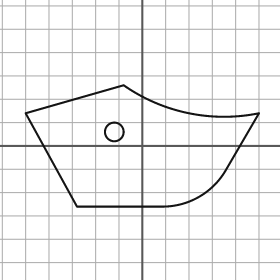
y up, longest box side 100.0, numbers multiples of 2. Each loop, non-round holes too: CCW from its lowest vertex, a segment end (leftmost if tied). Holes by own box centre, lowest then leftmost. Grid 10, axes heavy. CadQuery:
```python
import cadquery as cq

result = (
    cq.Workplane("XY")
    .moveTo(-28.0, -26.0)
    .lineTo(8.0, -26.0)
    .threePointArc((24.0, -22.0), (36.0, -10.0))
    .lineTo(50.0, 14.0)
    .threePointArc((20.0, 14.0), (-8.0, 26.0))
    .lineTo(-50.0, 14.0)
    .close()
    .moveTo(-12.0, 6.0)
    .circle(4.0)
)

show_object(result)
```